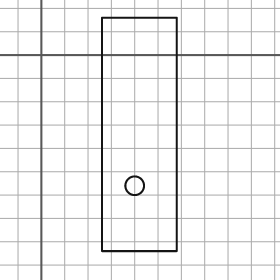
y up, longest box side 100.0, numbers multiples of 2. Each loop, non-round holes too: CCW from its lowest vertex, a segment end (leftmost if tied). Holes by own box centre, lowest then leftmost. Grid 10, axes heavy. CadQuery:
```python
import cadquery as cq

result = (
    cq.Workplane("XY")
    .moveTo(26.0, -84.0)
    .lineTo(58.0, -84.0)
    .lineTo(58.0, 16.0)
    .lineTo(26.0, 16.0)
    .close()
    .moveTo(40.0, -56.0)
    .circle(4.0)
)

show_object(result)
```